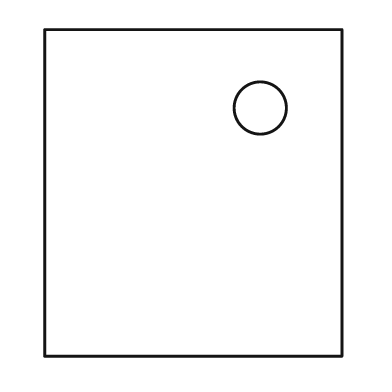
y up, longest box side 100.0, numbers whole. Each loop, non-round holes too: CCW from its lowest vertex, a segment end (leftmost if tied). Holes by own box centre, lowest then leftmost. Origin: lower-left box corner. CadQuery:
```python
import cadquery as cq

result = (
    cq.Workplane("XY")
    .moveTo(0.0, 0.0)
    .lineTo(91.0, 0.0)
    .lineTo(91.0, 100.0)
    .lineTo(0.0, 100.0)
    .close()
    .moveTo(66.0, 76.0)
    .circle(8.0)
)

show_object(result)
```